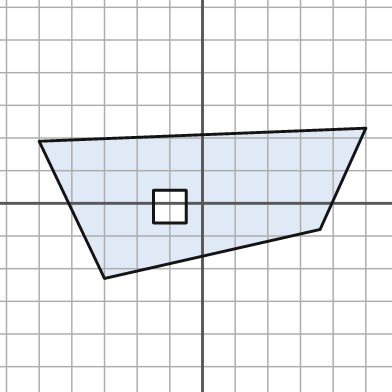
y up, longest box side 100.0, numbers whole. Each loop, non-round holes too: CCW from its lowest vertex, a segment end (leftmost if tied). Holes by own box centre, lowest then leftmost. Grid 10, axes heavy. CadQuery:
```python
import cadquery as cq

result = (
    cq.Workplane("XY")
    .moveTo(-30.0, -23.0)
    .lineTo(36.0, -8.0)
    .lineTo(50.0, 23.0)
    .lineTo(-50.0, 19.0)
    .close()
    .moveTo(-15.0, -6.0)
    .lineTo(-5.0, -6.0)
    .lineTo(-5.0, 4.0)
    .lineTo(-15.0, 4.0)
    .close()
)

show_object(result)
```